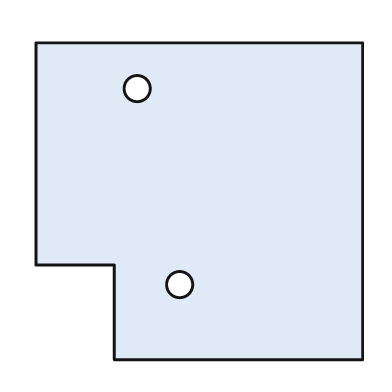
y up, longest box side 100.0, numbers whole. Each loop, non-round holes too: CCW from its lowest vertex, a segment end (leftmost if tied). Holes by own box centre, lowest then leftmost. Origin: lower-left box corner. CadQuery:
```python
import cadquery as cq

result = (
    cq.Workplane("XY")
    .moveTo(24.0, 0.0)
    .lineTo(100.0, 0.0)
    .lineTo(100.0, 97.0)
    .lineTo(0.0, 97.0)
    .lineTo(0.0, 29.0)
    .lineTo(24.0, 29.0)
    .close()
    .moveTo(44.0, 23.0)
    .circle(4.0)
    .moveTo(31.0, 83.0)
    .circle(4.0)
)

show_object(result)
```